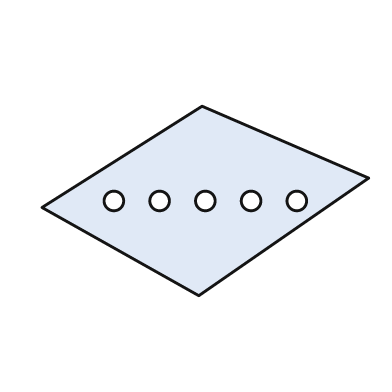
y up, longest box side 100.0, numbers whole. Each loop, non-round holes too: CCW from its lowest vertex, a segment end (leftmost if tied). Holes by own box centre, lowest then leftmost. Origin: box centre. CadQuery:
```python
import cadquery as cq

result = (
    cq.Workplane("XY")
    .moveTo(-2.0, -29.0)
    .lineTo(50.0, 7.0)
    .lineTo(-1.0, 29.0)
    .lineTo(-50.0, -2.0)
    .close()
    .moveTo(-28.0, 0.0)
    .circle(3.0)
    .moveTo(-14.0, 0.0)
    .circle(3.0)
    .moveTo(0.0, 0.0)
    .circle(3.0)
    .moveTo(14.0, 0.0)
    .circle(3.0)
    .moveTo(28.0, 0.0)
    .circle(3.0)
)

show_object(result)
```